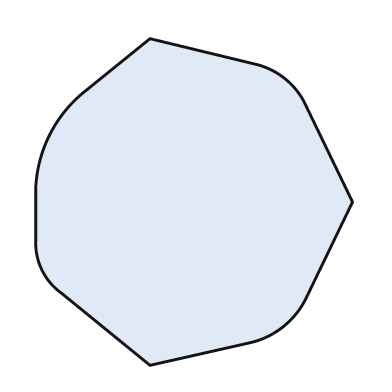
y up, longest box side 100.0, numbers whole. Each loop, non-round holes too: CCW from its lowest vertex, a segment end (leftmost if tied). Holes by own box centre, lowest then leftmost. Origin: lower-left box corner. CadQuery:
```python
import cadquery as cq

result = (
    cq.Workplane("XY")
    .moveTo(35.0, 0.0)
    .lineTo(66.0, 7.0)
    .threePointArc((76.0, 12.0), (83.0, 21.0))
    .lineTo(97.0, 50.0)
    .lineTo(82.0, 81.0)
    .threePointArc((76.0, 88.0), (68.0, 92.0))
    .lineTo(35.0, 100.0)
    .lineTo(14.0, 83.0)
    .threePointArc((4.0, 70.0), (0.0, 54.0))
    .lineTo(0.0, 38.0)
    .threePointArc((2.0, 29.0), (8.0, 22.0))
    .close()
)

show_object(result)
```